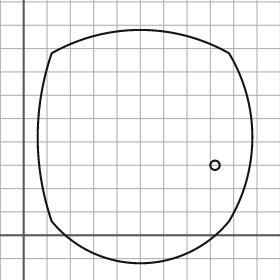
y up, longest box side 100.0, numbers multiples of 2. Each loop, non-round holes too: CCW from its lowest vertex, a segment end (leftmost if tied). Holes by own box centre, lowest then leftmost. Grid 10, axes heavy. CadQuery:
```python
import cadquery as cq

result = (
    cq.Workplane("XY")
    .moveTo(12.0, 6.0)
    .threePointArc((50.0, -12.0), (88.0, 6.0))
    .threePointArc((98.0, 42.0), (88.0, 78.0))
    .threePointArc((50.0, 88.0), (12.0, 78.0))
    .threePointArc((6.0, 42.0), (12.0, 6.0))
    .close()
    .moveTo(82.0, 30.0)
    .circle(2.0)
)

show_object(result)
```